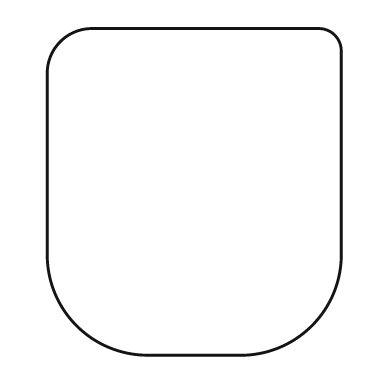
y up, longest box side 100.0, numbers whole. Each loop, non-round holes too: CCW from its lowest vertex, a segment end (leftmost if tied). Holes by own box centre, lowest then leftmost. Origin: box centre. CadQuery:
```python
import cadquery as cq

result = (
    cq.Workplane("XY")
    .moveTo(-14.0, -50.0)
    .lineTo(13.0, -50.0)
    .threePointArc((36.0, -41.0), (45.0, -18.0))
    .lineTo(45.0, 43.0)
    .threePointArc((43.0, 48.0), (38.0, 50.0))
    .lineTo(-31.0, 50.0)
    .threePointArc((-41.0, 46.0), (-45.0, 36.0))
    .lineTo(-45.0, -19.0)
    .threePointArc((-36.0, -41.0), (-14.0, -50.0))
    .close()
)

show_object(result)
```